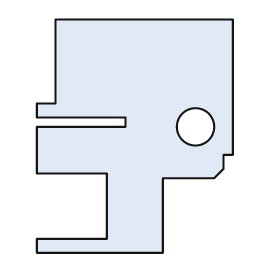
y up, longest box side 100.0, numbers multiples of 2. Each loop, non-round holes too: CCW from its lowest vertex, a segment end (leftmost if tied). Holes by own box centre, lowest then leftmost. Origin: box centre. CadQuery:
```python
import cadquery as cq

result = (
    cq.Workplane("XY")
    .moveTo(-42.0, -50.0)
    .lineTo(12.0, -50.0)
    .lineTo(12.0, -18.0)
    .lineTo(34.0, -18.0)
    .lineTo(38.0, -14.0)
    .lineTo(38.0, -8.0)
    .lineTo(42.0, -8.0)
    .lineTo(42.0, 50.0)
    .lineTo(-34.0, 50.0)
    .lineTo(-34.0, 14.0)
    .lineTo(-42.0, 14.0)
    .lineTo(-42.0, 8.0)
    .lineTo(-4.0, 8.0)
    .lineTo(-4.0, 4.0)
    .lineTo(-42.0, 4.0)
    .lineTo(-42.0, -16.0)
    .lineTo(-12.0, -16.0)
    .lineTo(-12.0, -44.0)
    .lineTo(-42.0, -44.0)
    .close()
    .moveTo(26.0, 4.0)
    .circle(8.0)
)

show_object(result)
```